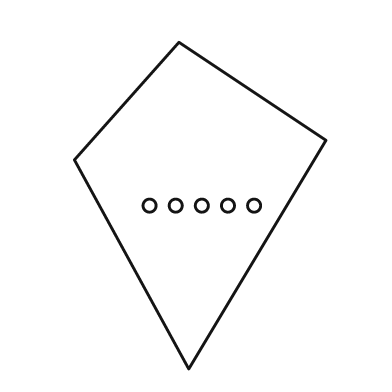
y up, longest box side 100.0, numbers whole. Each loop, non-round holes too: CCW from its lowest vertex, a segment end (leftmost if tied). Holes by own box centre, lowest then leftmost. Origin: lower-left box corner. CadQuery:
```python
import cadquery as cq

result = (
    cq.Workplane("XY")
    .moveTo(35.0, 0.0)
    .lineTo(77.0, 70.0)
    .lineTo(32.0, 100.0)
    .lineTo(0.0, 64.0)
    .close()
    .moveTo(23.0, 50.0)
    .circle(2.0)
    .moveTo(31.0, 50.0)
    .circle(2.0)
    .moveTo(39.0, 50.0)
    .circle(2.0)
    .moveTo(47.0, 50.0)
    .circle(2.0)
    .moveTo(55.0, 50.0)
    .circle(2.0)
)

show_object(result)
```